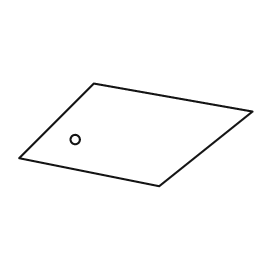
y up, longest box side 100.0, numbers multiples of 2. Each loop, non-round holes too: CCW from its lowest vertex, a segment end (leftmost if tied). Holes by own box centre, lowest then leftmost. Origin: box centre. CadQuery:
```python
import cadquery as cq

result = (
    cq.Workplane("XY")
    .moveTo(10.0, -22.0)
    .lineTo(50.0, 10.0)
    .lineTo(-18.0, 22.0)
    .lineTo(-50.0, -10.0)
    .close()
    .moveTo(-26.0, -2.0)
    .circle(2.0)
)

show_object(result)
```